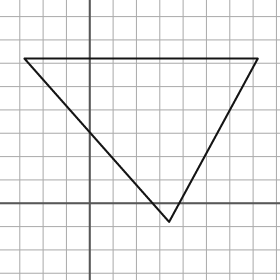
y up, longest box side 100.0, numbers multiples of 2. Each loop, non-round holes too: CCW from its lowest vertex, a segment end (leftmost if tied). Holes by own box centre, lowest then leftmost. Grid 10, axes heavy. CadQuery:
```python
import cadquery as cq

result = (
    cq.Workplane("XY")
    .moveTo(34.0, -8.0)
    .lineTo(72.0, 62.0)
    .lineTo(-28.0, 62.0)
    .close()
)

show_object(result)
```